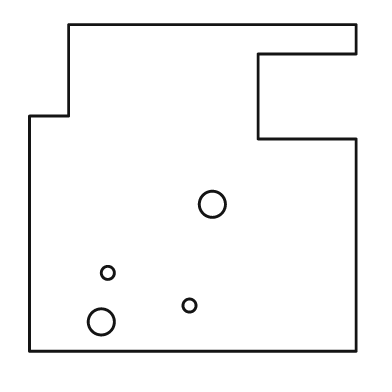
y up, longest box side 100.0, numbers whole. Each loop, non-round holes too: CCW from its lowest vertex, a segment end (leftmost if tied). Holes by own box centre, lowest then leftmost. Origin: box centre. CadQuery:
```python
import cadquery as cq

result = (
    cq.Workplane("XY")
    .moveTo(-50.0, -50.0)
    .lineTo(50.0, -50.0)
    .lineTo(50.0, 15.0)
    .lineTo(20.0, 15.0)
    .lineTo(20.0, 41.0)
    .lineTo(50.0, 41.0)
    .lineTo(50.0, 50.0)
    .lineTo(-38.0, 50.0)
    .lineTo(-38.0, 22.0)
    .lineTo(-50.0, 22.0)
    .close()
    .moveTo(-28.0, -41.0)
    .circle(4.0)
    .moveTo(-1.0, -36.0)
    .circle(2.0)
    .moveTo(-26.0, -26.0)
    .circle(2.0)
    .moveTo(6.0, -5.0)
    .circle(4.0)
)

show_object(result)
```